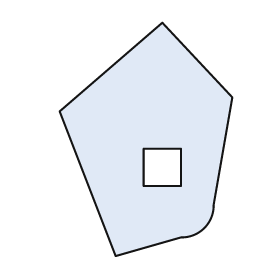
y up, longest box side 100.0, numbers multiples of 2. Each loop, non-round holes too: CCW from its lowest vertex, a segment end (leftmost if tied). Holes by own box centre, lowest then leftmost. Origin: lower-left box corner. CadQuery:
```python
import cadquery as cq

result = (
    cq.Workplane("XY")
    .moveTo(24.0, 0.0)
    .lineTo(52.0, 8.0)
    .threePointArc((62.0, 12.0), (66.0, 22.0))
    .lineTo(74.0, 68.0)
    .lineTo(44.0, 100.0)
    .lineTo(0.0, 62.0)
    .close()
    .moveTo(36.0, 30.0)
    .lineTo(52.0, 30.0)
    .lineTo(52.0, 46.0)
    .lineTo(36.0, 46.0)
    .close()
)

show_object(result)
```